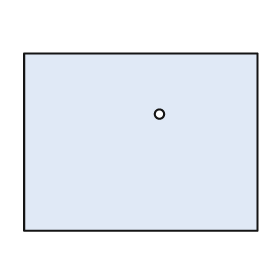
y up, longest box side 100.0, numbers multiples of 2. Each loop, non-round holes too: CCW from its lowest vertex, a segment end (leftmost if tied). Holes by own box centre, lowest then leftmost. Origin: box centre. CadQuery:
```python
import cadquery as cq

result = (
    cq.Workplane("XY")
    .moveTo(-50.0, -38.0)
    .lineTo(50.0, -38.0)
    .lineTo(50.0, 38.0)
    .lineTo(-50.0, 38.0)
    .close()
    .moveTo(8.0, 12.0)
    .circle(2.0)
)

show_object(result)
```